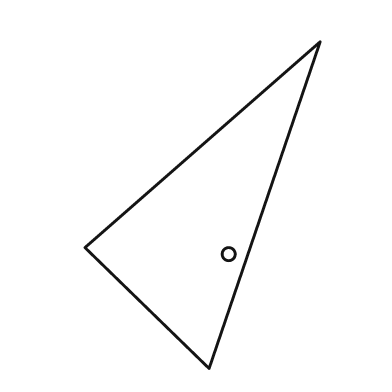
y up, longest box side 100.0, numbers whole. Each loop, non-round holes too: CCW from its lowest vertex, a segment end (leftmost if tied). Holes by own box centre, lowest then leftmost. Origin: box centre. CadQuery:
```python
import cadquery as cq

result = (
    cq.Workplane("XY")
    .moveTo(2.0, -50.0)
    .lineTo(36.0, 50.0)
    .lineTo(-36.0, -13.0)
    .close()
    .moveTo(8.0, -15.0)
    .circle(2.0)
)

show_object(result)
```